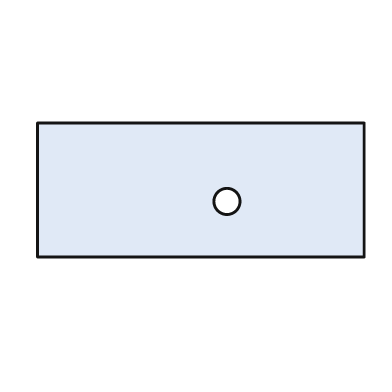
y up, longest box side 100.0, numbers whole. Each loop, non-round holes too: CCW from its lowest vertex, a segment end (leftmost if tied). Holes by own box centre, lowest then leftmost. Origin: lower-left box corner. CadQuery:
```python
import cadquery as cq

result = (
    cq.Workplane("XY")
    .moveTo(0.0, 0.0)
    .lineTo(100.0, 0.0)
    .lineTo(100.0, 41.0)
    .lineTo(0.0, 41.0)
    .close()
    .moveTo(58.0, 17.0)
    .circle(4.0)
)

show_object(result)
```